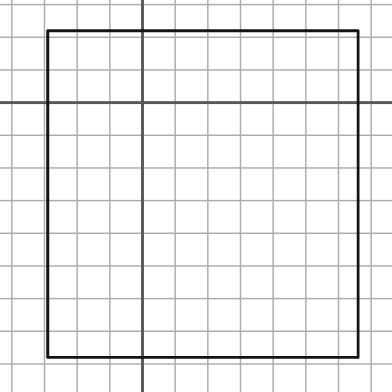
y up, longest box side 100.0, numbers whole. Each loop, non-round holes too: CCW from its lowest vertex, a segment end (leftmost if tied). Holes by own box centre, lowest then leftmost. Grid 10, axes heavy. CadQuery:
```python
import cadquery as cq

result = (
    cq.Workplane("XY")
    .moveTo(-29.0, -78.0)
    .lineTo(66.0, -78.0)
    .lineTo(66.0, 22.0)
    .lineTo(-29.0, 22.0)
    .close()
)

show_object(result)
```